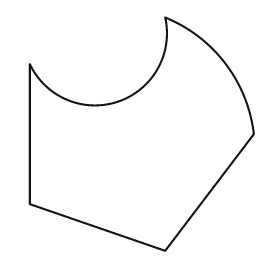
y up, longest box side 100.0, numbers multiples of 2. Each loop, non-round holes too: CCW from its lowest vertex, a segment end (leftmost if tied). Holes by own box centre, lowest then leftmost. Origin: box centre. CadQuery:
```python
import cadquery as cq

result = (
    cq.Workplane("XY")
    .moveTo(10.0, -50.0)
    .lineTo(48.0, 0.0)
    .threePointArc((36.0, 30.0), (10.0, 50.0))
    .threePointArc((-10.0, 14.0), (-48.0, 30.0))
    .lineTo(-48.0, -30.0)
    .close()
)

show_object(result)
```